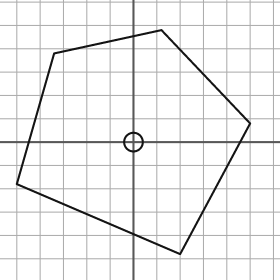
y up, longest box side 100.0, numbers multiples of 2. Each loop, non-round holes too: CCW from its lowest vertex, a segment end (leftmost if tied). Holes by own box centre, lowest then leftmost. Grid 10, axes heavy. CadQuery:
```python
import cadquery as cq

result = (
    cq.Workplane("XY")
    .moveTo(20.0, -48.0)
    .lineTo(50.0, 8.0)
    .lineTo(12.0, 48.0)
    .lineTo(-34.0, 38.0)
    .lineTo(-50.0, -18.0)
    .close()
    .moveTo(0.0, 0.0)
    .circle(4.0)
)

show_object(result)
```